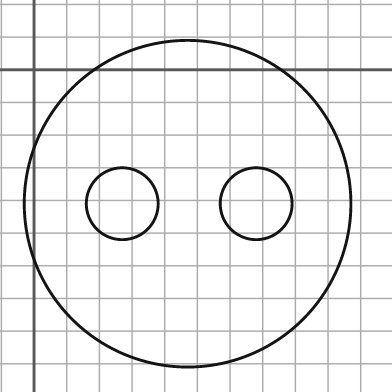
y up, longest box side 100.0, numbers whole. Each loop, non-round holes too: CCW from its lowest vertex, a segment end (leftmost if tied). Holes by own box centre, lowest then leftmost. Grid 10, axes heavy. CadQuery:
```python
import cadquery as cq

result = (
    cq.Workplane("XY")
    .moveTo(47.0, -41.0)
    .circle(50.0)
    .moveTo(27.0, -41.0)
    .circle(11.0)
    .moveTo(68.0, -41.0)
    .circle(11.0)
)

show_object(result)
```